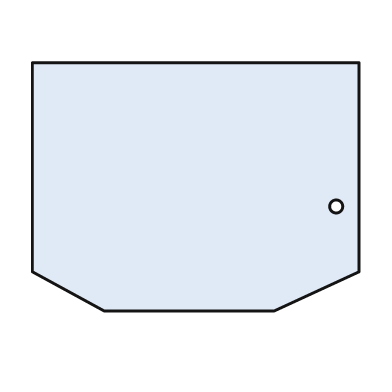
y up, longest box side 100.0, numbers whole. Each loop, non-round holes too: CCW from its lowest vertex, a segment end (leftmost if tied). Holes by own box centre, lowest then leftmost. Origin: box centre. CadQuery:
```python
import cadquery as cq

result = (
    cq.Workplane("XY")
    .moveTo(-28.0, -38.0)
    .lineTo(24.0, -38.0)
    .lineTo(50.0, -26.0)
    .lineTo(50.0, 38.0)
    .lineTo(-50.0, 38.0)
    .lineTo(-50.0, -26.0)
    .close()
    .moveTo(43.0, -6.0)
    .circle(2.0)
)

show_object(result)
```